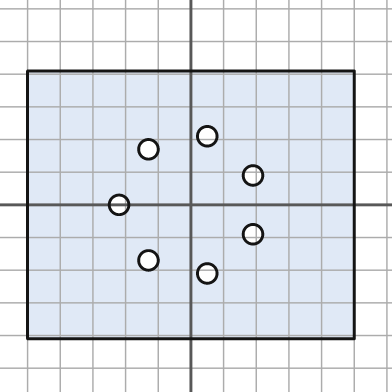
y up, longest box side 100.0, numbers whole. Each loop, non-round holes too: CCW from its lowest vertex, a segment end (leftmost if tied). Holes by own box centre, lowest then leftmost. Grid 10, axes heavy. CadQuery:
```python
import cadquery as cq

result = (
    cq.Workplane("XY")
    .moveTo(-50.0, -41.0)
    .lineTo(50.0, -41.0)
    .lineTo(50.0, 41.0)
    .lineTo(-50.0, 41.0)
    .close()
    .moveTo(5.0, -21.0)
    .circle(3.0)
    .moveTo(-13.0, -17.0)
    .circle(3.0)
    .moveTo(19.0, -9.0)
    .circle(3.0)
    .moveTo(-22.0, 0.0)
    .circle(3.0)
    .moveTo(19.0, 9.0)
    .circle(3.0)
    .moveTo(-13.0, 17.0)
    .circle(3.0)
    .moveTo(5.0, 21.0)
    .circle(3.0)
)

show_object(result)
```